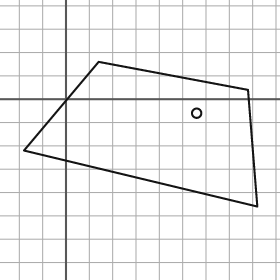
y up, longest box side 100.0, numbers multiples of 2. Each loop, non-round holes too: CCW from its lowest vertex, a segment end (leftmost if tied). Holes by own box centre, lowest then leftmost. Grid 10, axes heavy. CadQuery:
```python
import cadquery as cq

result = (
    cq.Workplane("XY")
    .moveTo(82.0, -46.0)
    .lineTo(78.0, 4.0)
    .lineTo(14.0, 16.0)
    .lineTo(-18.0, -22.0)
    .close()
    .moveTo(56.0, -6.0)
    .circle(2.0)
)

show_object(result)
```